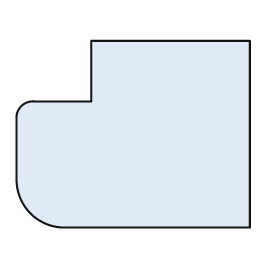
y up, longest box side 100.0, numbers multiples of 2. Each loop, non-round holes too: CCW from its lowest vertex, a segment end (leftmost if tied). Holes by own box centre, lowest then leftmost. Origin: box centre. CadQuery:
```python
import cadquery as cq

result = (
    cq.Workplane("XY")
    .moveTo(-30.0, -40.0)
    .lineTo(50.0, -40.0)
    .lineTo(50.0, 40.0)
    .lineTo(-18.0, 40.0)
    .lineTo(-18.0, 14.0)
    .lineTo(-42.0, 14.0)
    .threePointArc((-48.0, 12.0), (-50.0, 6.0))
    .lineTo(-50.0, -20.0)
    .threePointArc((-44.0, -34.0), (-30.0, -40.0))
    .close()
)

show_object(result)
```